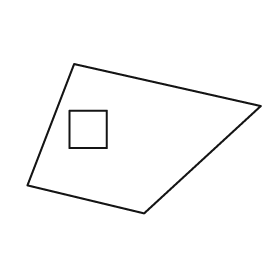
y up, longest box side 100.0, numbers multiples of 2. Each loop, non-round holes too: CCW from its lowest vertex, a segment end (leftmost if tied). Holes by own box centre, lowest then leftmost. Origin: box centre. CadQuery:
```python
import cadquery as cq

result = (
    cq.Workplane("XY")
    .moveTo(0.0, -32.0)
    .lineTo(50.0, 14.0)
    .lineTo(-30.0, 32.0)
    .lineTo(-50.0, -20.0)
    .close()
    .moveTo(-32.0, -4.0)
    .lineTo(-16.0, -4.0)
    .lineTo(-16.0, 12.0)
    .lineTo(-32.0, 12.0)
    .close()
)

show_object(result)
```